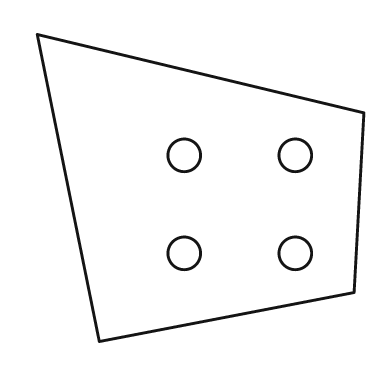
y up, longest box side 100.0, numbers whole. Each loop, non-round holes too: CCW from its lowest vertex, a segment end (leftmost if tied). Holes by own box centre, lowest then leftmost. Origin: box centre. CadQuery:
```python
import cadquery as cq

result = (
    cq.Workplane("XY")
    .moveTo(-31.0, -47.0)
    .lineTo(47.0, -32.0)
    .lineTo(50.0, 23.0)
    .lineTo(-50.0, 47.0)
    .close()
    .moveTo(-5.0, -20.0)
    .circle(5.0)
    .moveTo(29.0, -20.0)
    .circle(5.0)
    .moveTo(-5.0, 10.0)
    .circle(5.0)
    .moveTo(29.0, 10.0)
    .circle(5.0)
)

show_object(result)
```